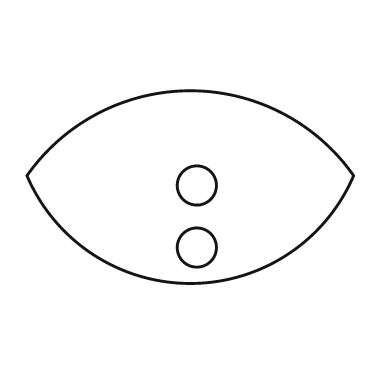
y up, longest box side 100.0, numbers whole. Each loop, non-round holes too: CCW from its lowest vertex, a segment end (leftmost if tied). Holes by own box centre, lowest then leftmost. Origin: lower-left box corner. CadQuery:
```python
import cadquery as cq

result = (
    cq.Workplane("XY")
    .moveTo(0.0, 33.0)
    .threePointArc((50.0, 0.0), (100.0, 33.0))
    .threePointArc((50.0, 59.0), (0.0, 33.0))
    .close()
    .moveTo(52.0, 11.0)
    .circle(6.0)
    .moveTo(52.0, 30.0)
    .circle(6.0)
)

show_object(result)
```